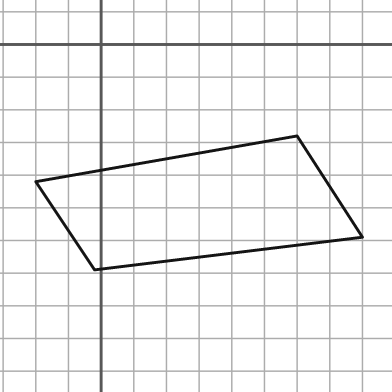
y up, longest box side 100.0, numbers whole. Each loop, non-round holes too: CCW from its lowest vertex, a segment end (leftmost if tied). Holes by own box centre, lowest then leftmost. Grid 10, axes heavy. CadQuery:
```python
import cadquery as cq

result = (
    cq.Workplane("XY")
    .moveTo(-2.0, -69.0)
    .lineTo(80.0, -59.0)
    .lineTo(60.0, -28.0)
    .lineTo(-20.0, -42.0)
    .close()
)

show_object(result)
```